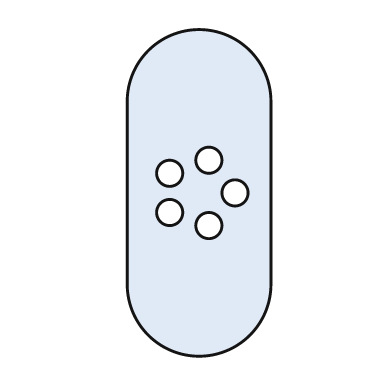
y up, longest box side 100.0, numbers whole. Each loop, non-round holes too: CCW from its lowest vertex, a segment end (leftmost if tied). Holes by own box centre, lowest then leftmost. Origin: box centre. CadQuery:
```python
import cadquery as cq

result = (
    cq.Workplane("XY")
    .moveTo(-22.0, -28.0)
    .threePointArc((0.0, -50.0), (22.0, -28.0))
    .lineTo(22.0, 28.0)
    .threePointArc((0.0, 50.0), (-22.0, 28.0))
    .close()
    .moveTo(3.0, -10.0)
    .circle(4.0)
    .moveTo(-9.0, -6.0)
    .circle(4.0)
    .moveTo(11.0, 0.0)
    .circle(4.0)
    .moveTo(-9.0, 6.0)
    .circle(4.0)
    .moveTo(3.0, 10.0)
    .circle(4.0)
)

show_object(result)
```